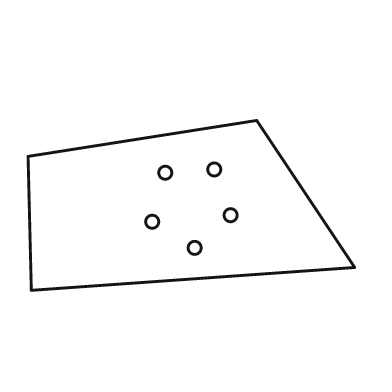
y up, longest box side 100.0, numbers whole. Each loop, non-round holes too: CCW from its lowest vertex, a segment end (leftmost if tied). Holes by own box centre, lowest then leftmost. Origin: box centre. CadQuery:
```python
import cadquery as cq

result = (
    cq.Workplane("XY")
    .moveTo(-49.0, -26.0)
    .lineTo(50.0, -19.0)
    .lineTo(20.0, 26.0)
    .lineTo(-50.0, 15.0)
    .close()
    .moveTo(1.0, -13.0)
    .circle(2.0)
    .moveTo(-12.0, -5.0)
    .circle(2.0)
    .moveTo(12.0, -3.0)
    .circle(2.0)
    .moveTo(-8.0, 10.0)
    .circle(2.0)
    .moveTo(7.0, 11.0)
    .circle(2.0)
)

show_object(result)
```